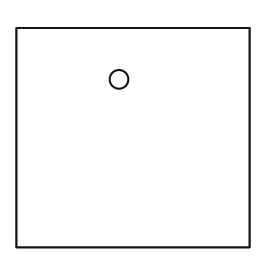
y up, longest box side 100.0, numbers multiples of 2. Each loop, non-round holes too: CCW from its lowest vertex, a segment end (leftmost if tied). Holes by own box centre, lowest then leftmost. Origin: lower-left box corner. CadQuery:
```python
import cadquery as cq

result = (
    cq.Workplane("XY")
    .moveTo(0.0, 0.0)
    .lineTo(100.0, 0.0)
    .lineTo(100.0, 94.0)
    .lineTo(0.0, 94.0)
    .close()
    .moveTo(44.0, 72.0)
    .circle(4.0)
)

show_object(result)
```